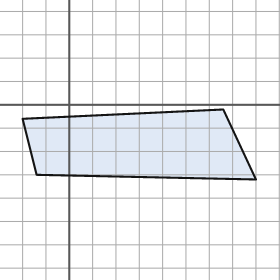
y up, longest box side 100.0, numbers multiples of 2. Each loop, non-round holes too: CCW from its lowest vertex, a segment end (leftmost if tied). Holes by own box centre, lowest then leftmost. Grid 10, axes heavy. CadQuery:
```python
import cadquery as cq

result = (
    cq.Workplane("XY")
    .moveTo(80.0, -32.0)
    .lineTo(66.0, -2.0)
    .lineTo(-20.0, -6.0)
    .lineTo(-14.0, -30.0)
    .close()
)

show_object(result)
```